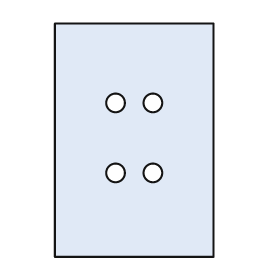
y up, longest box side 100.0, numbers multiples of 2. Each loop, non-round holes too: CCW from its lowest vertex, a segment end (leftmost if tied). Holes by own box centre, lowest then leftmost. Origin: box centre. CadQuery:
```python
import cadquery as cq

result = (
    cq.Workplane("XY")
    .moveTo(-34.0, -50.0)
    .lineTo(34.0, -50.0)
    .lineTo(34.0, 50.0)
    .lineTo(-34.0, 50.0)
    .close()
    .moveTo(-8.0, -14.0)
    .circle(4.0)
    .moveTo(8.0, -14.0)
    .circle(4.0)
    .moveTo(-8.0, 16.0)
    .circle(4.0)
    .moveTo(8.0, 16.0)
    .circle(4.0)
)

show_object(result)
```